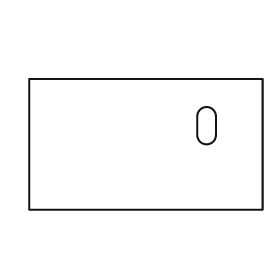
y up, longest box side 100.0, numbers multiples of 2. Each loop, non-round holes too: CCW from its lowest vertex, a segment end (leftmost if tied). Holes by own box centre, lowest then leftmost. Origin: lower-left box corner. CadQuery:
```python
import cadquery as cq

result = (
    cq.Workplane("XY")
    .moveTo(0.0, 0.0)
    .lineTo(100.0, 0.0)
    .lineTo(100.0, 56.0)
    .lineTo(0.0, 56.0)
    .close()
    .moveTo(72.0, 32.0)
    .threePointArc((76.0, 28.0), (80.0, 32.0))
    .lineTo(80.0, 40.0)
    .threePointArc((76.0, 44.0), (72.0, 40.0))
    .close()
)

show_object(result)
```